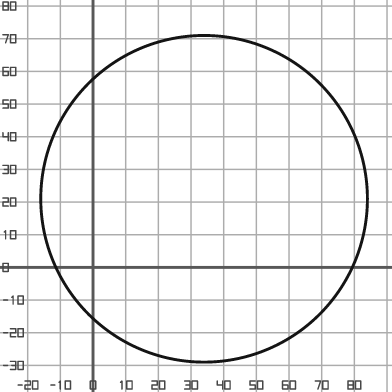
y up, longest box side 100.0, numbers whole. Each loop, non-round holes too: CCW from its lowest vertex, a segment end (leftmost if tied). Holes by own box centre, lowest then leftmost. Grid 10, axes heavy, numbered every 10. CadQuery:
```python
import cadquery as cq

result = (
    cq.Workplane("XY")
    .moveTo(34.0, 21.0)
    .circle(50.0)
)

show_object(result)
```